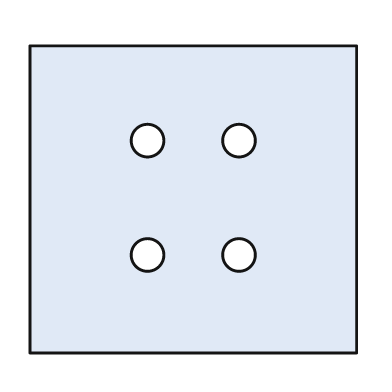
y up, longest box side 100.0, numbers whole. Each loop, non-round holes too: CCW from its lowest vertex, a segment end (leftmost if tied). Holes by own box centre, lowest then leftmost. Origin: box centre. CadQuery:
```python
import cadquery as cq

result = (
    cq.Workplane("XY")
    .moveTo(-50.0, -47.0)
    .lineTo(50.0, -47.0)
    .lineTo(50.0, 47.0)
    .lineTo(-50.0, 47.0)
    .close()
    .moveTo(-14.0, -17.0)
    .circle(5.0)
    .moveTo(14.0, -17.0)
    .circle(5.0)
    .moveTo(-14.0, 18.0)
    .circle(5.0)
    .moveTo(14.0, 18.0)
    .circle(5.0)
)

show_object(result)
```